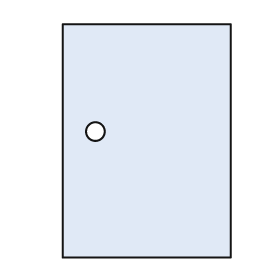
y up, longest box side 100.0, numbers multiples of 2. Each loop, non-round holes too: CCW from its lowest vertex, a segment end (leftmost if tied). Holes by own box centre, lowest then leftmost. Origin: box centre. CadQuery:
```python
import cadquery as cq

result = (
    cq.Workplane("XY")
    .moveTo(-36.0, -50.0)
    .lineTo(36.0, -50.0)
    .lineTo(36.0, 50.0)
    .lineTo(-36.0, 50.0)
    .close()
    .moveTo(-22.0, 4.0)
    .circle(4.0)
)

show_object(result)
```